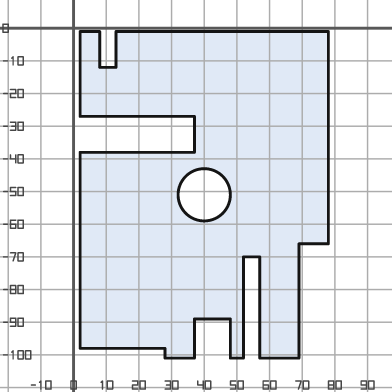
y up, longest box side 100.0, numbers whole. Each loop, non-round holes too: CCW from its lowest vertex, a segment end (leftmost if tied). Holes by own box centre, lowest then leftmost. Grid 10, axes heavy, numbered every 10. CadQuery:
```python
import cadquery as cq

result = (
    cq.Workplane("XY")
    .moveTo(28.0, -101.0)
    .lineTo(37.0, -101.0)
    .lineTo(37.0, -89.0)
    .lineTo(48.0, -89.0)
    .lineTo(48.0, -101.0)
    .lineTo(52.0, -101.0)
    .lineTo(52.0, -70.0)
    .lineTo(57.0, -70.0)
    .lineTo(57.0, -101.0)
    .lineTo(69.0, -101.0)
    .lineTo(69.0, -66.0)
    .lineTo(78.0, -66.0)
    .lineTo(78.0, -1.0)
    .lineTo(13.0, -1.0)
    .lineTo(13.0, -12.0)
    .lineTo(8.0, -12.0)
    .lineTo(8.0, -1.0)
    .lineTo(2.0, -1.0)
    .lineTo(2.0, -27.0)
    .lineTo(37.0, -27.0)
    .lineTo(37.0, -38.0)
    .lineTo(2.0, -38.0)
    .lineTo(2.0, -98.0)
    .lineTo(28.0, -98.0)
    .close()
    .moveTo(40.0, -51.0)
    .circle(8.0)
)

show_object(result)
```